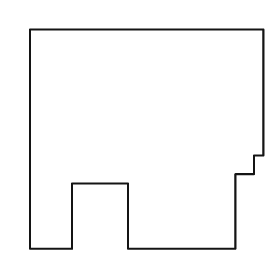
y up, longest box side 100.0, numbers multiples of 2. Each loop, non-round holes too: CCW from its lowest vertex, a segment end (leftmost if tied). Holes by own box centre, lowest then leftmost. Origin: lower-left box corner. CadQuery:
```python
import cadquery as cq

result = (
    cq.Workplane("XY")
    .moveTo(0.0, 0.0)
    .lineTo(18.0, 0.0)
    .lineTo(18.0, 28.0)
    .lineTo(42.0, 28.0)
    .lineTo(42.0, 0.0)
    .lineTo(88.0, 0.0)
    .lineTo(88.0, 32.0)
    .lineTo(96.0, 32.0)
    .lineTo(96.0, 40.0)
    .lineTo(100.0, 40.0)
    .lineTo(100.0, 94.0)
    .lineTo(0.0, 94.0)
    .close()
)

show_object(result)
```